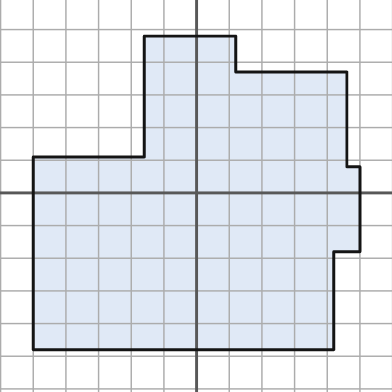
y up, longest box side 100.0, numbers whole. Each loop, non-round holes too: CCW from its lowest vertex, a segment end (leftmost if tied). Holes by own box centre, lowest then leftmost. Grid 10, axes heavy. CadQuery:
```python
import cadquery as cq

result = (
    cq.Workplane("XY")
    .moveTo(-50.0, -48.0)
    .lineTo(42.0, -48.0)
    .lineTo(42.0, -18.0)
    .lineTo(50.0, -18.0)
    .lineTo(50.0, 8.0)
    .lineTo(46.0, 8.0)
    .lineTo(46.0, 37.0)
    .lineTo(12.0, 37.0)
    .lineTo(12.0, 48.0)
    .lineTo(-16.0, 48.0)
    .lineTo(-16.0, 11.0)
    .lineTo(-50.0, 11.0)
    .close()
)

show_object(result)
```